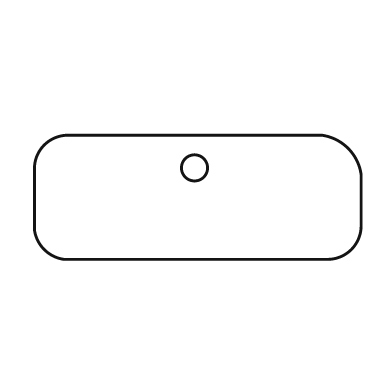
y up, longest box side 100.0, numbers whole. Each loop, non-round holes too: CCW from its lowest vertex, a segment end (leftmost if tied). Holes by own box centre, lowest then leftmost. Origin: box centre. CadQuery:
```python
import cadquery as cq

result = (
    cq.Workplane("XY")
    .moveTo(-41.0, -19.0)
    .lineTo(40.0, -19.0)
    .threePointArc((47.0, -16.0), (50.0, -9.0))
    .lineTo(50.0, 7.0)
    .threePointArc((46.0, 15.0), (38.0, 19.0))
    .lineTo(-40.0, 19.0)
    .threePointArc((-47.0, 16.0), (-50.0, 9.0))
    .lineTo(-50.0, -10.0)
    .threePointArc((-47.0, -16.0), (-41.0, -19.0))
    .close()
    .moveTo(-1.0, 9.0)
    .circle(4.0)
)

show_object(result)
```